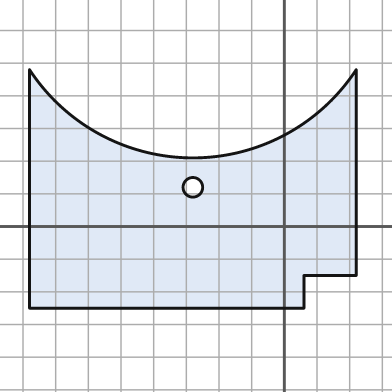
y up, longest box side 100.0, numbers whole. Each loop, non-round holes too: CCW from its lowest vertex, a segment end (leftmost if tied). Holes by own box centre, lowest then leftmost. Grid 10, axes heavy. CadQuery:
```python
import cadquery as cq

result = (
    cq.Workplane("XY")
    .moveTo(-78.0, -25.0)
    .lineTo(6.0, -25.0)
    .lineTo(6.0, -15.0)
    .lineTo(22.0, -15.0)
    .lineTo(22.0, 48.0)
    .threePointArc((-28.0, 21.0), (-78.0, 48.0))
    .close()
    .moveTo(-28.0, 12.0)
    .circle(3.0)
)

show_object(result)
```